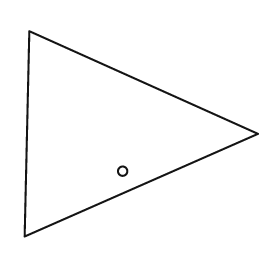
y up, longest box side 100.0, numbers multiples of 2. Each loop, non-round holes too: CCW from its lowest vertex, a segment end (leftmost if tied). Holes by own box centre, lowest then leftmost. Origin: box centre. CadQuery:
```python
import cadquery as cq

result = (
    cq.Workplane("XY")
    .moveTo(-50.0, -44.0)
    .lineTo(50.0, 0.0)
    .lineTo(-48.0, 44.0)
    .close()
    .moveTo(-8.0, -16.0)
    .circle(2.0)
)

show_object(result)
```